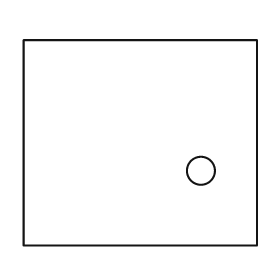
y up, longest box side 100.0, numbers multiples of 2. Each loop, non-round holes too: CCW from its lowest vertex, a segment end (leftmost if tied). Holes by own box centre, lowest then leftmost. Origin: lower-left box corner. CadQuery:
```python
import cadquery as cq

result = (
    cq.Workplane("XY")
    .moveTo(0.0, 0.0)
    .lineTo(100.0, 0.0)
    .lineTo(100.0, 88.0)
    .lineTo(0.0, 88.0)
    .close()
    .moveTo(76.0, 32.0)
    .circle(6.0)
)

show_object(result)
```